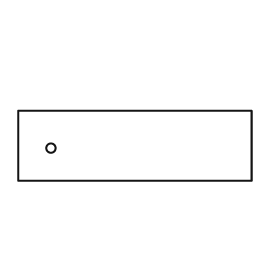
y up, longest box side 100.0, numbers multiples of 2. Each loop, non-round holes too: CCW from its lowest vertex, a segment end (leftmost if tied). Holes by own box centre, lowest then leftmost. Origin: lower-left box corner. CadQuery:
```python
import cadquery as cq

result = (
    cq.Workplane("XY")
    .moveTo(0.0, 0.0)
    .lineTo(100.0, 0.0)
    .lineTo(100.0, 30.0)
    .lineTo(0.0, 30.0)
    .close()
    .moveTo(14.0, 14.0)
    .circle(2.0)
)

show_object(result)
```